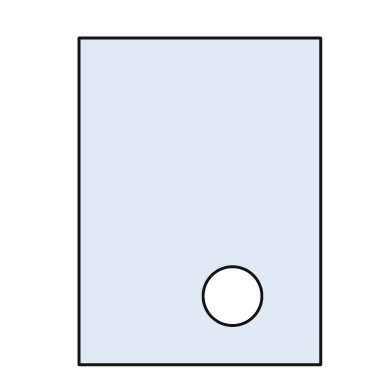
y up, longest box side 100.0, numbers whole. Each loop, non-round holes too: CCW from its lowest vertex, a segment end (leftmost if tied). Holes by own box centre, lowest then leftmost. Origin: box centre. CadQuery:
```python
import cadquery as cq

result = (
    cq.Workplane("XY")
    .moveTo(-37.0, -50.0)
    .lineTo(37.0, -50.0)
    .lineTo(37.0, 50.0)
    .lineTo(-37.0, 50.0)
    .close()
    .moveTo(10.0, -29.0)
    .circle(9.0)
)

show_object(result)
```